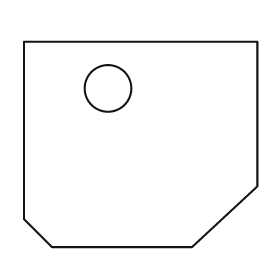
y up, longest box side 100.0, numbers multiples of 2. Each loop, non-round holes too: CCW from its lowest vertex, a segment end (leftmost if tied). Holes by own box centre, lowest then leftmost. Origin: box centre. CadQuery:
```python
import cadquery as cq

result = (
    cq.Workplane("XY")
    .moveTo(-38.0, -44.0)
    .lineTo(22.0, -44.0)
    .lineTo(50.0, -18.0)
    .lineTo(50.0, 44.0)
    .lineTo(-50.0, 44.0)
    .lineTo(-50.0, -32.0)
    .close()
    .moveTo(-14.0, 24.0)
    .circle(10.0)
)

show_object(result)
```